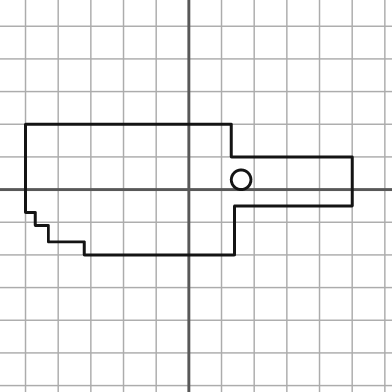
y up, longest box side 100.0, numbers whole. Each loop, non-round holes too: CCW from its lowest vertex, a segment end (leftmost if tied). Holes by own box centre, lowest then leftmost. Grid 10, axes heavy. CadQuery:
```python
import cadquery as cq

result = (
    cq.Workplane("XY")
    .moveTo(-32.0, -20.0)
    .lineTo(14.0, -20.0)
    .lineTo(14.0, -5.0)
    .lineTo(50.0, -5.0)
    .lineTo(50.0, 10.0)
    .lineTo(13.0, 10.0)
    .lineTo(13.0, 20.0)
    .lineTo(-50.0, 20.0)
    .lineTo(-50.0, -7.0)
    .lineTo(-47.0, -7.0)
    .lineTo(-47.0, -11.0)
    .lineTo(-43.0, -11.0)
    .lineTo(-43.0, -16.0)
    .lineTo(-32.0, -16.0)
    .close()
    .moveTo(16.0, 3.0)
    .circle(3.0)
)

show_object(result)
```